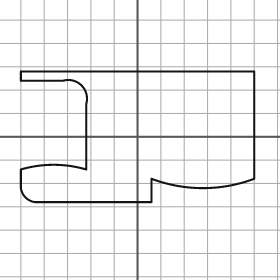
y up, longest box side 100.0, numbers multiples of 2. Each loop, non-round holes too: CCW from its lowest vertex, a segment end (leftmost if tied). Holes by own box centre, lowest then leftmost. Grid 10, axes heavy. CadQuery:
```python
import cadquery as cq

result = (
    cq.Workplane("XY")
    .moveTo(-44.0, -28.0)
    .lineTo(6.0, -28.0)
    .lineTo(6.0, -18.0)
    .threePointArc((28.0, -22.0), (50.0, -18.0))
    .lineTo(50.0, 28.0)
    .lineTo(-50.0, 28.0)
    .lineTo(-50.0, 24.0)
    .lineTo(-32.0, 24.0)
    .threePointArc((-24.0, 22.0), (-22.0, 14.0))
    .lineTo(-22.0, -14.0)
    .threePointArc((-36.0, -12.0), (-50.0, -14.0))
    .lineTo(-50.0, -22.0)
    .threePointArc((-48.0, -26.0), (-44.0, -28.0))
    .close()
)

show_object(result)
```